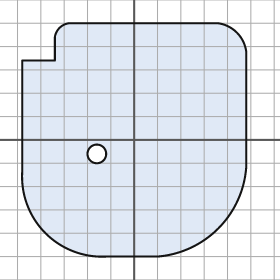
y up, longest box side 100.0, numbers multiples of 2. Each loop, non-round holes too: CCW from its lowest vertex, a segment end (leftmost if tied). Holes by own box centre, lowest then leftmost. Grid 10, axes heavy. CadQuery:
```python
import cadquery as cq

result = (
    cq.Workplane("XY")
    .moveTo(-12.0, -50.0)
    .lineTo(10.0, -50.0)
    .threePointArc((36.0, -38.0), (48.0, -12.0))
    .lineTo(48.0, 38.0)
    .threePointArc((44.0, 46.0), (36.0, 50.0))
    .lineTo(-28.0, 50.0)
    .threePointArc((-32.0, 48.0), (-34.0, 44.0))
    .lineTo(-34.0, 34.0)
    .lineTo(-48.0, 34.0)
    .lineTo(-48.0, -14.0)
    .threePointArc((-38.0, -40.0), (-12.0, -50.0))
    .close()
    .moveTo(-16.0, -6.0)
    .circle(4.0)
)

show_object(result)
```